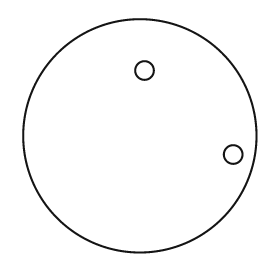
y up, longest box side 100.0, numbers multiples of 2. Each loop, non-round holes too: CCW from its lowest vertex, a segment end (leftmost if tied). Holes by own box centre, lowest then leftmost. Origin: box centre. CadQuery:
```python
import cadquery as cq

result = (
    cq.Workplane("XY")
    .moveTo(0.0, 0.0)
    .circle(50.0)
    .moveTo(40.0, -8.0)
    .circle(4.0)
    .moveTo(2.0, 28.0)
    .circle(4.0)
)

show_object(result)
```